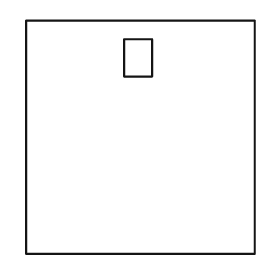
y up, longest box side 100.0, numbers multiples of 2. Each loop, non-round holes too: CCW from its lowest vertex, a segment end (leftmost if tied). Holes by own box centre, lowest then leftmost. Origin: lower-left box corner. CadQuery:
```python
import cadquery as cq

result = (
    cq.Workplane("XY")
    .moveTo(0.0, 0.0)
    .lineTo(98.0, 0.0)
    .lineTo(98.0, 100.0)
    .lineTo(0.0, 100.0)
    .close()
    .moveTo(42.0, 76.0)
    .lineTo(54.0, 76.0)
    .lineTo(54.0, 92.0)
    .lineTo(42.0, 92.0)
    .close()
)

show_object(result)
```